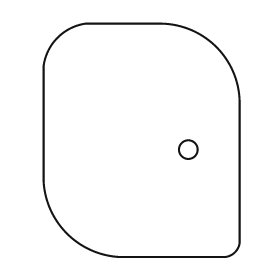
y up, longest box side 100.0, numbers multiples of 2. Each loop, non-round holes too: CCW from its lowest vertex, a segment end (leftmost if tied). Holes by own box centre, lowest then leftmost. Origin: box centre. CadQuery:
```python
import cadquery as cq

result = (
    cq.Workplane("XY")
    .moveTo(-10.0, -50.0)
    .lineTo(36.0, -50.0)
    .threePointArc((40.0, -48.0), (42.0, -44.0))
    .lineTo(42.0, 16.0)
    .threePointArc((32.0, 40.0), (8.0, 50.0))
    .lineTo(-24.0, 50.0)
    .threePointArc((-36.0, 44.0), (-42.0, 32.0))
    .lineTo(-42.0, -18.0)
    .threePointArc((-32.0, -40.0), (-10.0, -50.0))
    .close()
    .moveTo(20.0, -4.0)
    .circle(4.0)
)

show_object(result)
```